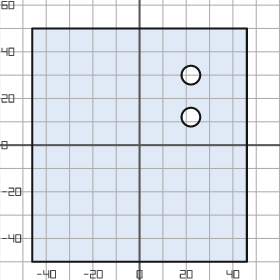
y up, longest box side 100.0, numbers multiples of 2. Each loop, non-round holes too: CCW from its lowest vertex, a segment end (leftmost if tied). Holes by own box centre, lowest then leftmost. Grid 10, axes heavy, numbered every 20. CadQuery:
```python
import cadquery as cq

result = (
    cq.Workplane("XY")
    .moveTo(-46.0, -50.0)
    .lineTo(46.0, -50.0)
    .lineTo(46.0, 50.0)
    .lineTo(-46.0, 50.0)
    .close()
    .moveTo(22.0, 12.0)
    .circle(4.0)
    .moveTo(22.0, 30.0)
    .circle(4.0)
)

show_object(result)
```